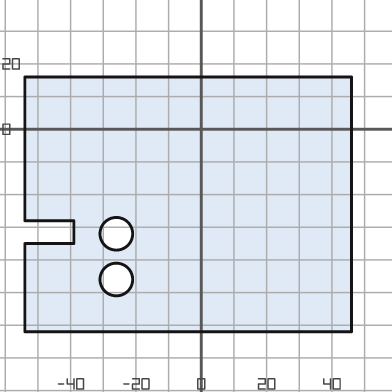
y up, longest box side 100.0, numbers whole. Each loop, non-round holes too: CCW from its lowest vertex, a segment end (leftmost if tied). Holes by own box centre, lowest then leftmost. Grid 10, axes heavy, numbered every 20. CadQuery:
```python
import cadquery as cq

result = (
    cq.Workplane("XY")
    .moveTo(-54.0, -62.0)
    .lineTo(46.0, -62.0)
    .lineTo(46.0, 16.0)
    .lineTo(-54.0, 16.0)
    .lineTo(-54.0, -28.0)
    .lineTo(-39.0, -28.0)
    .lineTo(-39.0, -35.0)
    .lineTo(-54.0, -35.0)
    .close()
    .moveTo(-26.0, -46.0)
    .circle(5.0)
    .moveTo(-26.0, -32.0)
    .circle(5.0)
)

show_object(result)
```